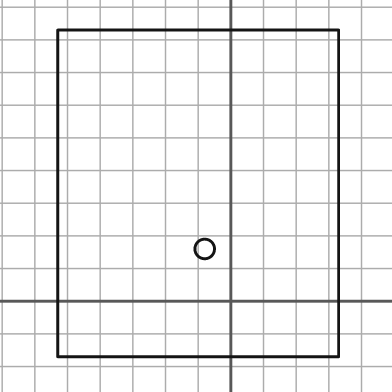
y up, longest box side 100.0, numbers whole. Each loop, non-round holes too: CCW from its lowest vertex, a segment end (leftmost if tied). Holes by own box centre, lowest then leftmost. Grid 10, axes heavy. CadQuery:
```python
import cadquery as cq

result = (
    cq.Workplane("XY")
    .moveTo(-53.0, -17.0)
    .lineTo(33.0, -17.0)
    .lineTo(33.0, 83.0)
    .lineTo(-53.0, 83.0)
    .close()
    .moveTo(-8.0, 16.0)
    .circle(3.0)
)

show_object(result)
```